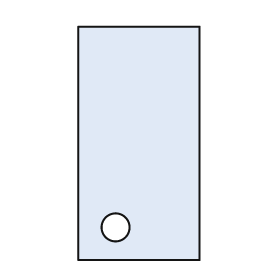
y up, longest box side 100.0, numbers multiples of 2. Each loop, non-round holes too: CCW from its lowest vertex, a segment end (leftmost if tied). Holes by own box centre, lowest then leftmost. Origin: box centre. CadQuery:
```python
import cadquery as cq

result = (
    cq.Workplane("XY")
    .moveTo(-26.0, -50.0)
    .lineTo(26.0, -50.0)
    .lineTo(26.0, 50.0)
    .lineTo(-26.0, 50.0)
    .close()
    .moveTo(-10.0, -36.0)
    .circle(6.0)
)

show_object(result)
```